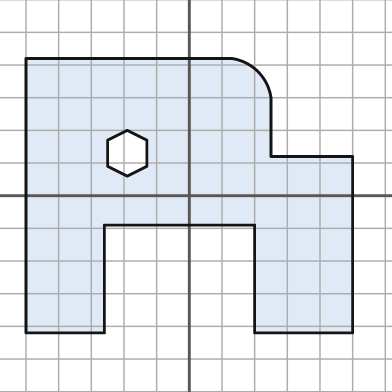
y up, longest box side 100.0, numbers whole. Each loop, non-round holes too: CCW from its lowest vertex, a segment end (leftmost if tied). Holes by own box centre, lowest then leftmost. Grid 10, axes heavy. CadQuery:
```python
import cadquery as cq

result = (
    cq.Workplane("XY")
    .moveTo(-50.0, -42.0)
    .lineTo(-26.0, -42.0)
    .lineTo(-26.0, -9.0)
    .lineTo(20.0, -9.0)
    .lineTo(20.0, -42.0)
    .lineTo(50.0, -42.0)
    .lineTo(50.0, 12.0)
    .lineTo(25.0, 12.0)
    .lineTo(25.0, 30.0)
    .threePointArc((21.0, 38.0), (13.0, 42.0))
    .lineTo(-50.0, 42.0)
    .close()
    .moveTo(-19.0, 6.0)
    .lineTo(-13.0, 9.0)
    .lineTo(-13.0, 17.0)
    .lineTo(-19.0, 20.0)
    .lineTo(-25.0, 17.0)
    .lineTo(-25.0, 9.0)
    .close()
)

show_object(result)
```